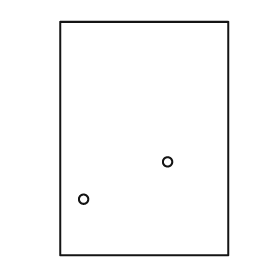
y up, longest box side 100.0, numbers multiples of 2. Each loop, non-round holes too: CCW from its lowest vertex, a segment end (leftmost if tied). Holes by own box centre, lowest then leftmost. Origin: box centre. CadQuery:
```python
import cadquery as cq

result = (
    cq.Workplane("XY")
    .moveTo(-36.0, -50.0)
    .lineTo(36.0, -50.0)
    .lineTo(36.0, 50.0)
    .lineTo(-36.0, 50.0)
    .close()
    .moveTo(-26.0, -26.0)
    .circle(2.0)
    .moveTo(10.0, -10.0)
    .circle(2.0)
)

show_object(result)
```